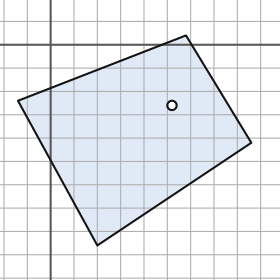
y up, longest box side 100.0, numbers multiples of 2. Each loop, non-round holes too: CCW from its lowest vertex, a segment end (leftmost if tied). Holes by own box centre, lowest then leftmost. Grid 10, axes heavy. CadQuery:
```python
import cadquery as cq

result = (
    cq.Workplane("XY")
    .moveTo(20.0, -86.0)
    .lineTo(86.0, -42.0)
    .lineTo(58.0, 4.0)
    .lineTo(-14.0, -24.0)
    .close()
    .moveTo(52.0, -26.0)
    .circle(2.0)
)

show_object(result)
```